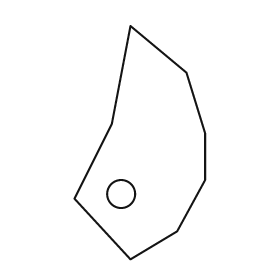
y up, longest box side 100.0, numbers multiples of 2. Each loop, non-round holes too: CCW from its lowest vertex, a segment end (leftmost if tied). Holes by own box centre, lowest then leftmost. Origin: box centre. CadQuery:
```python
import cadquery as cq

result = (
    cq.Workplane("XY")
    .moveTo(-4.0, -50.0)
    .lineTo(16.0, -38.0)
    .lineTo(28.0, -16.0)
    .lineTo(28.0, 4.0)
    .lineTo(20.0, 30.0)
    .lineTo(-4.0, 50.0)
    .lineTo(-12.0, 8.0)
    .lineTo(-28.0, -24.0)
    .close()
    .moveTo(-8.0, -22.0)
    .circle(6.0)
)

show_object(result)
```